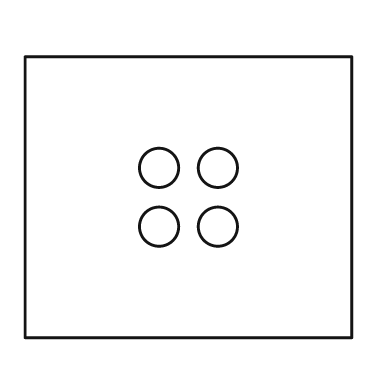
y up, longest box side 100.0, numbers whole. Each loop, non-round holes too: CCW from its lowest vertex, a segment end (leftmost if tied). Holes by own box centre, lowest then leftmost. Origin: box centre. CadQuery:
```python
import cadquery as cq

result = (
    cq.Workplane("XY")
    .moveTo(-50.0, -43.0)
    .lineTo(50.0, -43.0)
    .lineTo(50.0, 43.0)
    .lineTo(-50.0, 43.0)
    .close()
    .moveTo(-9.0, -9.0)
    .circle(6.0)
    .moveTo(9.0, -9.0)
    .circle(6.0)
    .moveTo(-9.0, 9.0)
    .circle(6.0)
    .moveTo(9.0, 9.0)
    .circle(6.0)
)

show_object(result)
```